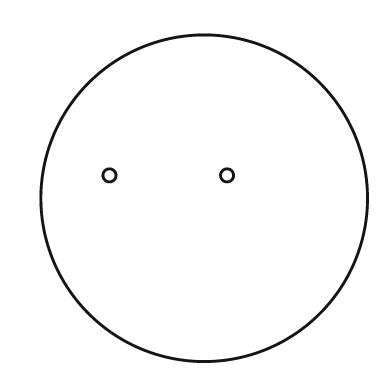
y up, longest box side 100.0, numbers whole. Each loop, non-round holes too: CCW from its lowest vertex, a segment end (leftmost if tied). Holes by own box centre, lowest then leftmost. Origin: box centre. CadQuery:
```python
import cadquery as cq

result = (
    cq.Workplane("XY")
    .moveTo(0.0, 0.0)
    .circle(50.0)
    .moveTo(-29.0, 7.0)
    .circle(2.0)
    .moveTo(7.0, 7.0)
    .circle(2.0)
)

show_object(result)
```